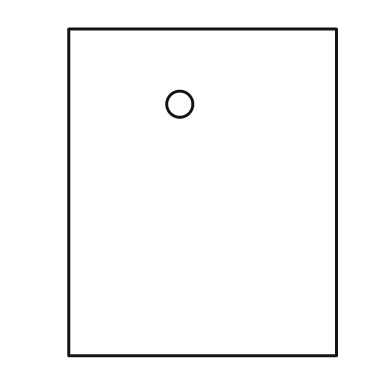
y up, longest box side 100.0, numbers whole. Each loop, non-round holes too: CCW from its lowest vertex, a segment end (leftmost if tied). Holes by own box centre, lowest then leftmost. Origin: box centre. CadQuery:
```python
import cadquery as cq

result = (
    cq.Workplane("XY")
    .moveTo(-41.0, -50.0)
    .lineTo(41.0, -50.0)
    .lineTo(41.0, 50.0)
    .lineTo(-41.0, 50.0)
    .close()
    .moveTo(-7.0, 27.0)
    .circle(4.0)
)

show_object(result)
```